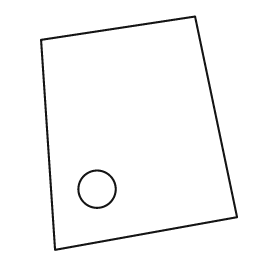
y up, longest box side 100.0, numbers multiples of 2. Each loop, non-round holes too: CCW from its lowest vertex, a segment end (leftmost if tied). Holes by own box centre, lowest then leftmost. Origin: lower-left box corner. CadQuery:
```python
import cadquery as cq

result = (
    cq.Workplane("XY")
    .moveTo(6.0, 0.0)
    .lineTo(84.0, 14.0)
    .lineTo(66.0, 100.0)
    .lineTo(0.0, 90.0)
    .close()
    .moveTo(24.0, 26.0)
    .circle(8.0)
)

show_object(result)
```